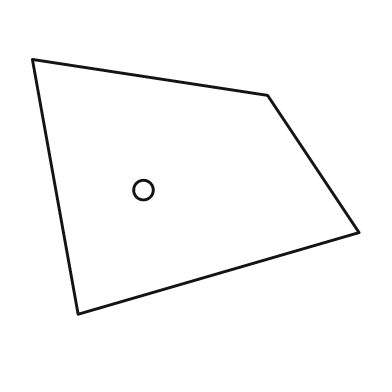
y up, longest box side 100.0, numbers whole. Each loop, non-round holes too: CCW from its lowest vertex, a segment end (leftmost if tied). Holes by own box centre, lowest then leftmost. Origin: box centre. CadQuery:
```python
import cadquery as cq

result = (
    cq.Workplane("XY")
    .moveTo(-36.0, -39.0)
    .lineTo(50.0, -14.0)
    .lineTo(22.0, 28.0)
    .lineTo(-50.0, 39.0)
    .close()
    .moveTo(-16.0, -1.0)
    .circle(3.0)
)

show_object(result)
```